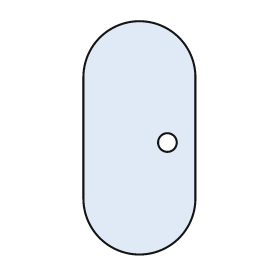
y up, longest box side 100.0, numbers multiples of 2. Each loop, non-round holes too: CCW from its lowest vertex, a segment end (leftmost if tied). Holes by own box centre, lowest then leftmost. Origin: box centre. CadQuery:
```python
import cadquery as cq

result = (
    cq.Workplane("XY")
    .moveTo(-24.0, -26.0)
    .threePointArc((0.0, -50.0), (24.0, -26.0))
    .lineTo(24.0, 26.0)
    .threePointArc((0.0, 50.0), (-24.0, 26.0))
    .close()
    .moveTo(12.0, -2.0)
    .circle(4.0)
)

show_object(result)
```